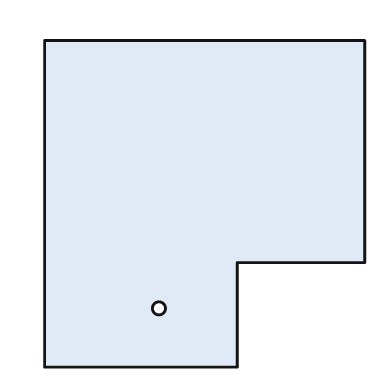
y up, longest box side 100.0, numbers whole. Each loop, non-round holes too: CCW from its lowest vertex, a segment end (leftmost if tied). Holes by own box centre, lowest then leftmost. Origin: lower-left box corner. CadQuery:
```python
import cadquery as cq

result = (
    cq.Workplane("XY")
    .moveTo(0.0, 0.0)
    .lineTo(59.0, 0.0)
    .lineTo(59.0, 32.0)
    .lineTo(98.0, 32.0)
    .lineTo(98.0, 100.0)
    .lineTo(0.0, 100.0)
    .close()
    .moveTo(35.0, 18.0)
    .circle(2.0)
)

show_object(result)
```